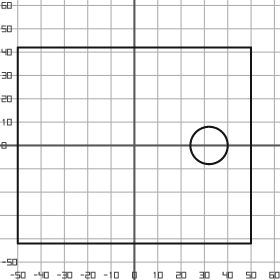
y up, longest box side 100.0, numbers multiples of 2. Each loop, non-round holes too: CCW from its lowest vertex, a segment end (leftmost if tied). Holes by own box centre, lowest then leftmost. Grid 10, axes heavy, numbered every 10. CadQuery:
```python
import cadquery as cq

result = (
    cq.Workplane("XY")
    .moveTo(-50.0, -42.0)
    .lineTo(50.0, -42.0)
    .lineTo(50.0, 42.0)
    .lineTo(-50.0, 42.0)
    .close()
    .moveTo(32.0, 0.0)
    .circle(8.0)
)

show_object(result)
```